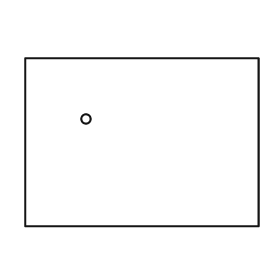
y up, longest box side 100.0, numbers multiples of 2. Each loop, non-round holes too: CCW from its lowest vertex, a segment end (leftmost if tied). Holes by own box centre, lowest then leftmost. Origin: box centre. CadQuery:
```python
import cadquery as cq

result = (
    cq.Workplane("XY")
    .moveTo(-50.0, -36.0)
    .lineTo(50.0, -36.0)
    .lineTo(50.0, 36.0)
    .lineTo(-50.0, 36.0)
    .close()
    .moveTo(-24.0, 10.0)
    .circle(2.0)
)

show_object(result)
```